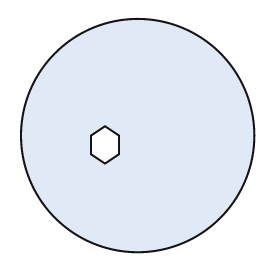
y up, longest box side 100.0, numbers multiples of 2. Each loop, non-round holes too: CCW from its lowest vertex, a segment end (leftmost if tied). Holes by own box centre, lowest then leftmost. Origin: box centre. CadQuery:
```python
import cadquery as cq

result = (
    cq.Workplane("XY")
    .moveTo(0.0, 0.0)
    .circle(50.0)
    .moveTo(-14.0, -12.0)
    .lineTo(-8.0, -8.0)
    .lineTo(-8.0, 0.0)
    .lineTo(-14.0, 4.0)
    .lineTo(-20.0, 0.0)
    .lineTo(-20.0, -8.0)
    .close()
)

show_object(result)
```